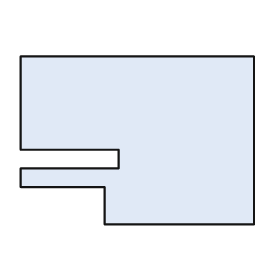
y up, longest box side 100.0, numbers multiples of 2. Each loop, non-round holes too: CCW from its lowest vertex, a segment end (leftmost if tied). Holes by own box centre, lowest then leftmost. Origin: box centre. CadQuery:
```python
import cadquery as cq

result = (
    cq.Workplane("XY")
    .moveTo(-14.0, -36.0)
    .lineTo(50.0, -36.0)
    .lineTo(50.0, 36.0)
    .lineTo(-50.0, 36.0)
    .lineTo(-50.0, -4.0)
    .lineTo(-8.0, -4.0)
    .lineTo(-8.0, -12.0)
    .lineTo(-50.0, -12.0)
    .lineTo(-50.0, -20.0)
    .lineTo(-14.0, -20.0)
    .close()
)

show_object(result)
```